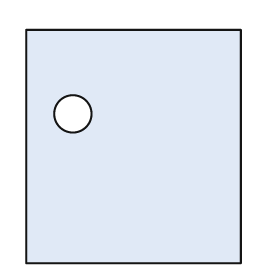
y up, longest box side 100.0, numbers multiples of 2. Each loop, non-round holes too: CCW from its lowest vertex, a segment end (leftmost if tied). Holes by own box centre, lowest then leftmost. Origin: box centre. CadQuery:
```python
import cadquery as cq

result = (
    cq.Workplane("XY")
    .moveTo(-46.0, -50.0)
    .lineTo(46.0, -50.0)
    .lineTo(46.0, 50.0)
    .lineTo(-46.0, 50.0)
    .close()
    .moveTo(-26.0, 14.0)
    .circle(8.0)
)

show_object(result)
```